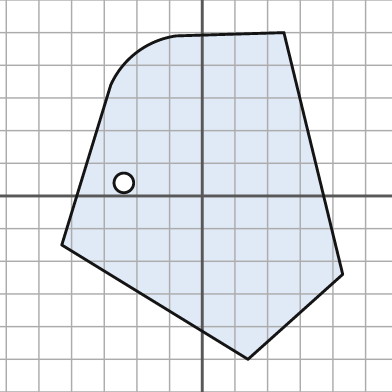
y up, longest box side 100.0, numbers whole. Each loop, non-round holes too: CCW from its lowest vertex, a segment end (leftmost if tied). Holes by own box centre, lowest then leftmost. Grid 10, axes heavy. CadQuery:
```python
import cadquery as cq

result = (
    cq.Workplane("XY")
    .moveTo(14.0, -50.0)
    .lineTo(43.0, -24.0)
    .lineTo(25.0, 50.0)
    .lineTo(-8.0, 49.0)
    .threePointArc((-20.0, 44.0), (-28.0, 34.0))
    .lineTo(-43.0, -15.0)
    .close()
    .moveTo(-24.0, 4.0)
    .circle(3.0)
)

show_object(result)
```